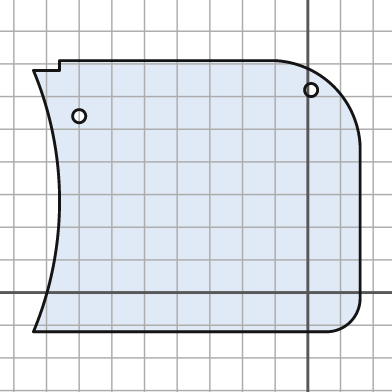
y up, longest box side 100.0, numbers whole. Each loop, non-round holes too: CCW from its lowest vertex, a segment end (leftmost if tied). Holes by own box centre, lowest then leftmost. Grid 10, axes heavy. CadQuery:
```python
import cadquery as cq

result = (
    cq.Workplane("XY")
    .moveTo(-84.0, -12.0)
    .lineTo(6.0, -12.0)
    .threePointArc((13.0, -9.0), (16.0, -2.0))
    .lineTo(16.0, 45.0)
    .threePointArc((8.0, 63.0), (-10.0, 71.0))
    .lineTo(-76.0, 71.0)
    .lineTo(-76.0, 68.0)
    .lineTo(-84.0, 68.0)
    .threePointArc((-76.0, 28.0), (-84.0, -12.0))
    .close()
    .moveTo(-70.0, 54.0)
    .circle(2.0)
    .moveTo(1.0, 62.0)
    .circle(2.0)
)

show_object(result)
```